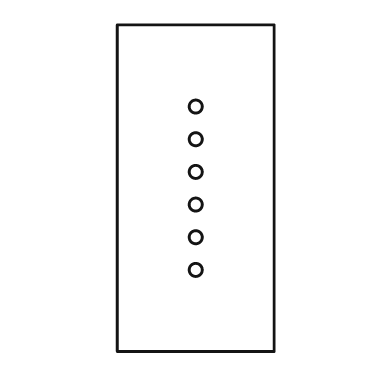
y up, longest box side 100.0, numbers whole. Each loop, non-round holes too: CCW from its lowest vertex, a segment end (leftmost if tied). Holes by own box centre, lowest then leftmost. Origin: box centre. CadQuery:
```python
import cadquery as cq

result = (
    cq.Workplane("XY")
    .moveTo(-24.0, -50.0)
    .lineTo(24.0, -50.0)
    .lineTo(24.0, 50.0)
    .lineTo(-24.0, 50.0)
    .close()
    .moveTo(0.0, -25.0)
    .circle(2.0)
    .moveTo(0.0, -15.0)
    .circle(2.0)
    .moveTo(0.0, -5.0)
    .circle(2.0)
    .moveTo(0.0, 5.0)
    .circle(2.0)
    .moveTo(0.0, 15.0)
    .circle(2.0)
    .moveTo(0.0, 25.0)
    .circle(2.0)
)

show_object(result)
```